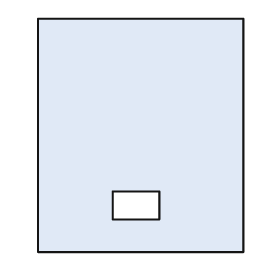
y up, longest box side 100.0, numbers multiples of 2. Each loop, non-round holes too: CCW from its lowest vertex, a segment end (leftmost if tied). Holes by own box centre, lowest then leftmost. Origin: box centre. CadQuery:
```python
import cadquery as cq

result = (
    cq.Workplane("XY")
    .moveTo(-44.0, -50.0)
    .lineTo(44.0, -50.0)
    .lineTo(44.0, 50.0)
    .lineTo(-44.0, 50.0)
    .close()
    .moveTo(-12.0, -36.0)
    .lineTo(8.0, -36.0)
    .lineTo(8.0, -24.0)
    .lineTo(-12.0, -24.0)
    .close()
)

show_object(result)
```